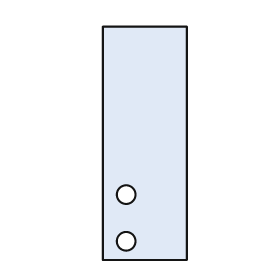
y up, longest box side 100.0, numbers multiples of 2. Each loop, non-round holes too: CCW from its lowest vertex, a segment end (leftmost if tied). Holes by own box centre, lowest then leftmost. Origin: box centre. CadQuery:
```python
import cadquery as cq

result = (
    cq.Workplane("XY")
    .moveTo(-18.0, -50.0)
    .lineTo(18.0, -50.0)
    .lineTo(18.0, 50.0)
    .lineTo(-18.0, 50.0)
    .close()
    .moveTo(-8.0, -42.0)
    .circle(4.0)
    .moveTo(-8.0, -22.0)
    .circle(4.0)
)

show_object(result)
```